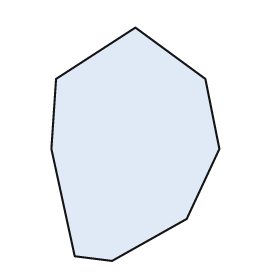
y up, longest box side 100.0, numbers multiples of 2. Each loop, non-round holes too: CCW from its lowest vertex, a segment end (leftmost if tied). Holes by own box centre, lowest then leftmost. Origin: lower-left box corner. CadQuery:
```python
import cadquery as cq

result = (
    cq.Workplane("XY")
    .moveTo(26.0, 0.0)
    .lineTo(58.0, 18.0)
    .lineTo(72.0, 48.0)
    .lineTo(66.0, 78.0)
    .lineTo(36.0, 100.0)
    .lineTo(2.0, 78.0)
    .lineTo(0.0, 48.0)
    .lineTo(10.0, 2.0)
    .close()
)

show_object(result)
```